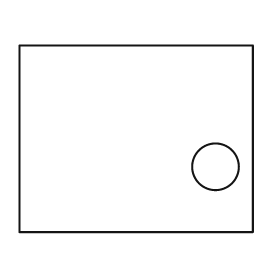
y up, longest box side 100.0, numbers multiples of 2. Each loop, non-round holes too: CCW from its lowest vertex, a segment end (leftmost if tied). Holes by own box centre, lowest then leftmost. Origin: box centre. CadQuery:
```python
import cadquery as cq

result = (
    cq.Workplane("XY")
    .moveTo(-50.0, -40.0)
    .lineTo(50.0, -40.0)
    .lineTo(50.0, 40.0)
    .lineTo(-50.0, 40.0)
    .close()
    .moveTo(34.0, -12.0)
    .circle(10.0)
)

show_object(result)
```